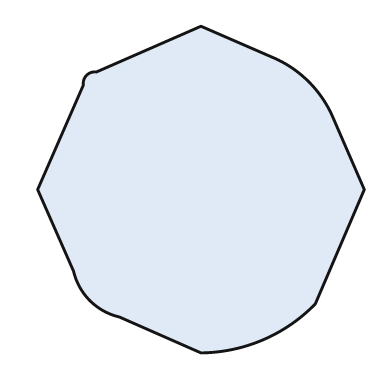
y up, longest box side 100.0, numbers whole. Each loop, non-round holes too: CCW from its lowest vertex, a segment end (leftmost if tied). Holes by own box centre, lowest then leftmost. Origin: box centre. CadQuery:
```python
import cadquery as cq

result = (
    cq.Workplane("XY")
    .moveTo(0.0, -50.0)
    .threePointArc((19.0, -46.0), (35.0, -35.0))
    .lineTo(50.0, 0.0)
    .lineTo(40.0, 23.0)
    .threePointArc((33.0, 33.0), (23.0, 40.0))
    .lineTo(0.0, 50.0)
    .lineTo(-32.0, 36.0)
    .threePointArc((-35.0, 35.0), (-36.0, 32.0))
    .lineTo(-50.0, 0.0)
    .lineTo(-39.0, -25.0)
    .threePointArc((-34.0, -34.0), (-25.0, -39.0))
    .close()
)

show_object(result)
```